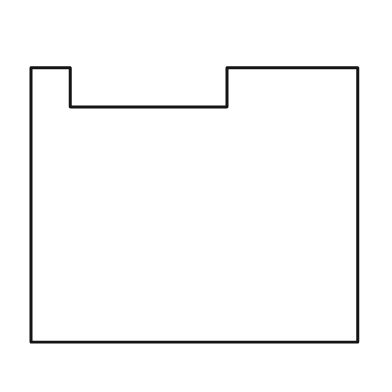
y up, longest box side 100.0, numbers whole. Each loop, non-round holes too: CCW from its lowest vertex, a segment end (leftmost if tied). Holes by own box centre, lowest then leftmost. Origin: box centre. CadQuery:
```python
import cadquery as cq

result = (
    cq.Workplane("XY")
    .moveTo(-50.0, -42.0)
    .lineTo(50.0, -42.0)
    .lineTo(50.0, 42.0)
    .lineTo(10.0, 42.0)
    .lineTo(10.0, 30.0)
    .lineTo(-38.0, 30.0)
    .lineTo(-38.0, 42.0)
    .lineTo(-50.0, 42.0)
    .close()
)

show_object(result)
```